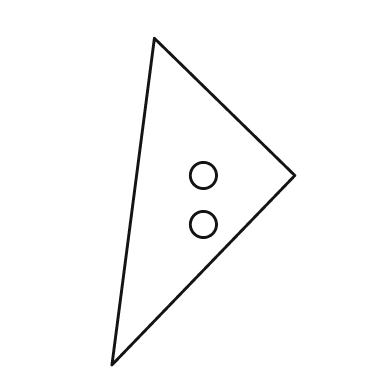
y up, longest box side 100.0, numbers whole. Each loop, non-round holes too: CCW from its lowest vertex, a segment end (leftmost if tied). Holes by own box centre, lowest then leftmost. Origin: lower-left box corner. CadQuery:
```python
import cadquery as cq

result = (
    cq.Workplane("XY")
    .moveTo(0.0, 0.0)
    .lineTo(56.0, 58.0)
    .lineTo(13.0, 100.0)
    .close()
    .moveTo(28.0, 43.0)
    .circle(4.0)
    .moveTo(28.0, 58.0)
    .circle(4.0)
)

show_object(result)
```